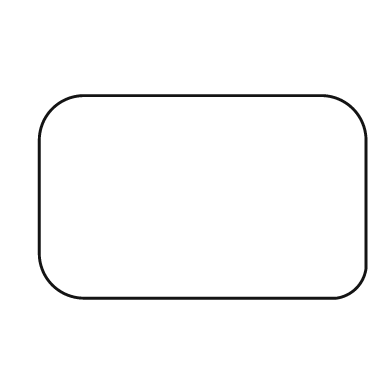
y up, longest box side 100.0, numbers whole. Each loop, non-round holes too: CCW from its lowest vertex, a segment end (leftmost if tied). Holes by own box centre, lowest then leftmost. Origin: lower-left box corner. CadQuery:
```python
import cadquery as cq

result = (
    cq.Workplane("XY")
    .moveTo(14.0, 0.0)
    .lineTo(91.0, 0.0)
    .threePointArc((97.0, 3.0), (100.0, 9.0))
    .lineTo(100.0, 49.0)
    .threePointArc((96.0, 58.0), (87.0, 62.0))
    .lineTo(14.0, 62.0)
    .threePointArc((4.0, 58.0), (0.0, 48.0))
    .lineTo(0.0, 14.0)
    .threePointArc((4.0, 4.0), (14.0, 0.0))
    .close()
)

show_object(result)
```